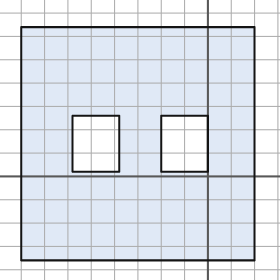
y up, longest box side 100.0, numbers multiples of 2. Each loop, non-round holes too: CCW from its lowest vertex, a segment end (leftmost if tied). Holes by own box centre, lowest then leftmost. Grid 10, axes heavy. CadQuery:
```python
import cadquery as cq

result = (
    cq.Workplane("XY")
    .moveTo(-80.0, -36.0)
    .lineTo(20.0, -36.0)
    .lineTo(20.0, 64.0)
    .lineTo(-80.0, 64.0)
    .close()
    .moveTo(-58.0, 2.0)
    .lineTo(-38.0, 2.0)
    .lineTo(-38.0, 26.0)
    .lineTo(-58.0, 26.0)
    .close()
    .moveTo(-20.0, 2.0)
    .lineTo(0.0, 2.0)
    .lineTo(0.0, 26.0)
    .lineTo(-20.0, 26.0)
    .close()
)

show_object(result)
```